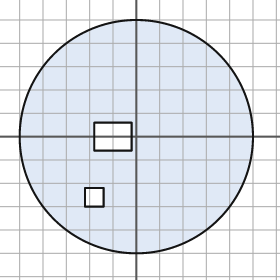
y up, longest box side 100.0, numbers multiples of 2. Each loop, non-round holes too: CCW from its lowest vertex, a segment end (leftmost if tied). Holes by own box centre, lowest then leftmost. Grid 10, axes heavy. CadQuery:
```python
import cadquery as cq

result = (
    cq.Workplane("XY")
    .moveTo(0.0, 0.0)
    .circle(50.0)
    .moveTo(-22.0, -30.0)
    .lineTo(-14.0, -30.0)
    .lineTo(-14.0, -22.0)
    .lineTo(-22.0, -22.0)
    .close()
    .moveTo(-18.0, -6.0)
    .lineTo(-2.0, -6.0)
    .lineTo(-2.0, 6.0)
    .lineTo(-18.0, 6.0)
    .close()
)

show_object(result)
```